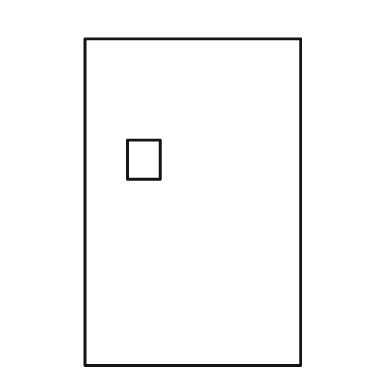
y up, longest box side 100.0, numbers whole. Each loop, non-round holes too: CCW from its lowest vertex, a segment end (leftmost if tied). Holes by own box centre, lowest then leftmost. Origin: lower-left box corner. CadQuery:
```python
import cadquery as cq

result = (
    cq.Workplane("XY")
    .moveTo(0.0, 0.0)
    .lineTo(66.0, 0.0)
    .lineTo(66.0, 100.0)
    .lineTo(0.0, 100.0)
    .close()
    .moveTo(13.0, 57.0)
    .lineTo(23.0, 57.0)
    .lineTo(23.0, 69.0)
    .lineTo(13.0, 69.0)
    .close()
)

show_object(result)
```